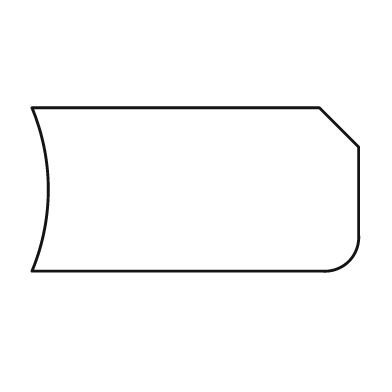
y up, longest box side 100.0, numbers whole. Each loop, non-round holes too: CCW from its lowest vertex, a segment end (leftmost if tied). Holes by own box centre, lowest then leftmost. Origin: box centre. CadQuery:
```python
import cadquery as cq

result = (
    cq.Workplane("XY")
    .moveTo(-50.0, -25.0)
    .lineTo(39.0, -25.0)
    .threePointArc((47.0, -22.0), (50.0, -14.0))
    .lineTo(50.0, 13.0)
    .lineTo(38.0, 25.0)
    .lineTo(-50.0, 25.0)
    .threePointArc((-45.0, 0.0), (-50.0, -25.0))
    .close()
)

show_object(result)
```